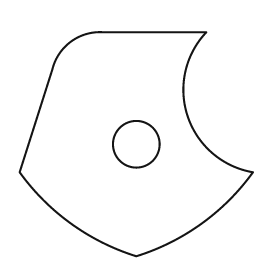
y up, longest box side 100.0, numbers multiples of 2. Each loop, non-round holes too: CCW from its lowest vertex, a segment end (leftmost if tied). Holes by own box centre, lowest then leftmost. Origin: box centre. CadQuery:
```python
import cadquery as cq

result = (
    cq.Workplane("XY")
    .moveTo(0.0, -48.0)
    .threePointArc((28.0, -34.0), (50.0, -12.0))
    .threePointArc((22.0, 12.0), (30.0, 48.0))
    .lineTo(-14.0, 48.0)
    .threePointArc((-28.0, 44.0), (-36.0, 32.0))
    .lineTo(-50.0, -12.0)
    .threePointArc((-28.0, -34.0), (0.0, -48.0))
    .close()
    .moveTo(0.0, 0.0)
    .circle(10.0)
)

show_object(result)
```